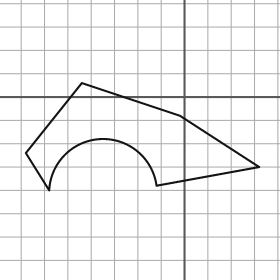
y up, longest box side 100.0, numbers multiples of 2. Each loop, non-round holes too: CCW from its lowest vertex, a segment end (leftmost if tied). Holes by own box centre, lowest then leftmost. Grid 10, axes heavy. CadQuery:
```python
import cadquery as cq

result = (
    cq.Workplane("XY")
    .moveTo(-58.0, -40.0)
    .threePointArc((-36.0, -18.0), (-12.0, -38.0))
    .lineTo(32.0, -30.0)
    .lineTo(-2.0, -8.0)
    .lineTo(-44.0, 6.0)
    .lineTo(-68.0, -24.0)
    .close()
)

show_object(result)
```